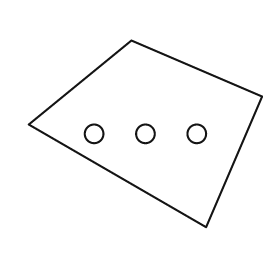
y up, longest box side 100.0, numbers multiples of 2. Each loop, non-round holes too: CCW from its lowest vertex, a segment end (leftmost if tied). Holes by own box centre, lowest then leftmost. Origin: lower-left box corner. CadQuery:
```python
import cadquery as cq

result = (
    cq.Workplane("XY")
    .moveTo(76.0, 0.0)
    .lineTo(100.0, 56.0)
    .lineTo(44.0, 80.0)
    .lineTo(0.0, 44.0)
    .close()
    .moveTo(28.0, 40.0)
    .circle(4.0)
    .moveTo(50.0, 40.0)
    .circle(4.0)
    .moveTo(72.0, 40.0)
    .circle(4.0)
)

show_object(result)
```